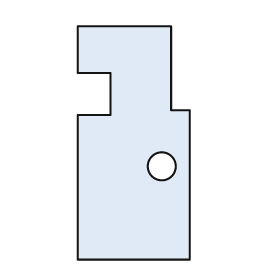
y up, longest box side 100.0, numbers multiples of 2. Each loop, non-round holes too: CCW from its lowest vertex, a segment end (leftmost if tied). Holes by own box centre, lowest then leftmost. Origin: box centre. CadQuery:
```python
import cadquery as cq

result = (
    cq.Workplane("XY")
    .moveTo(-24.0, -50.0)
    .lineTo(24.0, -50.0)
    .lineTo(24.0, 14.0)
    .lineTo(16.0, 14.0)
    .lineTo(16.0, 50.0)
    .lineTo(-24.0, 50.0)
    .lineTo(-24.0, 30.0)
    .lineTo(-10.0, 30.0)
    .lineTo(-10.0, 12.0)
    .lineTo(-24.0, 12.0)
    .close()
    .moveTo(12.0, -10.0)
    .circle(6.0)
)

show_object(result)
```